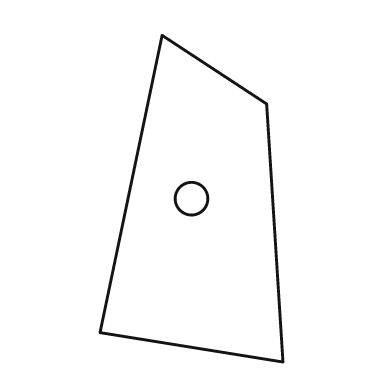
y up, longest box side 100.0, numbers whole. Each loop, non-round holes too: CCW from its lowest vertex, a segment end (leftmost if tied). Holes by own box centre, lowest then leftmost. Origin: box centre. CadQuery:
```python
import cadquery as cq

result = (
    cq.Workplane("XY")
    .moveTo(28.0, -50.0)
    .lineTo(23.0, 29.0)
    .lineTo(-9.0, 50.0)
    .lineTo(-28.0, -41.0)
    .close()
    .moveTo(0.0, 0.0)
    .circle(5.0)
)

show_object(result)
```